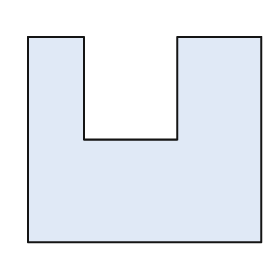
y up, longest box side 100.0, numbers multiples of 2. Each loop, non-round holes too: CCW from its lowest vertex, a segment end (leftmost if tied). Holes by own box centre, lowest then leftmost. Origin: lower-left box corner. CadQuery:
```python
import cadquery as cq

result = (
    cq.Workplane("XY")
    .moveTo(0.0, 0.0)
    .lineTo(100.0, 0.0)
    .lineTo(100.0, 88.0)
    .lineTo(64.0, 88.0)
    .lineTo(64.0, 44.0)
    .lineTo(24.0, 44.0)
    .lineTo(24.0, 88.0)
    .lineTo(0.0, 88.0)
    .close()
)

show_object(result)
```